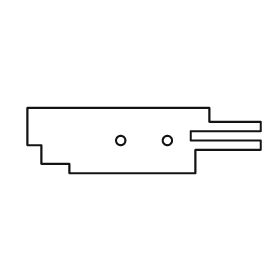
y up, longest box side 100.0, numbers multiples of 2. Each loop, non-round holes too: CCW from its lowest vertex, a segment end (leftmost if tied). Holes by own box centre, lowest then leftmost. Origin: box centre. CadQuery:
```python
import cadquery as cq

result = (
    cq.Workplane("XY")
    .moveTo(-32.0, -14.0)
    .lineTo(22.0, -14.0)
    .lineTo(22.0, -4.0)
    .lineTo(50.0, -4.0)
    .lineTo(50.0, 0.0)
    .lineTo(20.0, 0.0)
    .lineTo(20.0, 4.0)
    .lineTo(50.0, 4.0)
    .lineTo(50.0, 8.0)
    .lineTo(28.0, 8.0)
    .lineTo(28.0, 14.0)
    .lineTo(-50.0, 14.0)
    .lineTo(-50.0, -2.0)
    .lineTo(-44.0, -2.0)
    .lineTo(-44.0, -10.0)
    .lineTo(-32.0, -10.0)
    .close()
    .moveTo(-10.0, 0.0)
    .circle(2.0)
    .moveTo(10.0, 0.0)
    .circle(2.0)
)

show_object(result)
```